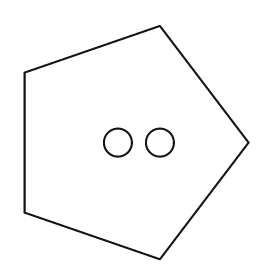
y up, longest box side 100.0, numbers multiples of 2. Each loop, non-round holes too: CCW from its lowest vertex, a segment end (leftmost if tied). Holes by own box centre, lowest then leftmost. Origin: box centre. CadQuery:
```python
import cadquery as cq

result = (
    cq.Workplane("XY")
    .moveTo(10.0, -50.0)
    .lineTo(48.0, 0.0)
    .lineTo(10.0, 50.0)
    .lineTo(-48.0, 30.0)
    .lineTo(-48.0, -30.0)
    .close()
    .moveTo(-8.0, 0.0)
    .circle(6.0)
    .moveTo(10.0, 0.0)
    .circle(6.0)
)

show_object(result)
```